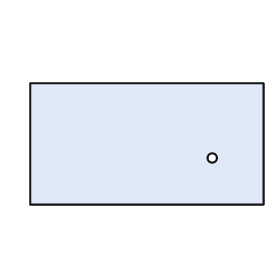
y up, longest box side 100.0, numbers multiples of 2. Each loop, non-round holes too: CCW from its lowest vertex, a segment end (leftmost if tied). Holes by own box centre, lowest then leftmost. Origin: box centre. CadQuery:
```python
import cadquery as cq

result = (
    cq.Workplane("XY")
    .moveTo(-50.0, -26.0)
    .lineTo(50.0, -26.0)
    .lineTo(50.0, 26.0)
    .lineTo(-50.0, 26.0)
    .close()
    .moveTo(28.0, -6.0)
    .circle(2.0)
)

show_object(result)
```